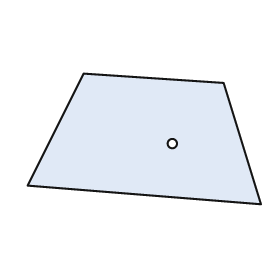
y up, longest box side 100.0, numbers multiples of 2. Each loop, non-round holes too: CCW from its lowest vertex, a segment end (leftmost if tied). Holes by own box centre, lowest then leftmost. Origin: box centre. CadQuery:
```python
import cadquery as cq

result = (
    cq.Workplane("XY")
    .moveTo(50.0, -28.0)
    .lineTo(34.0, 24.0)
    .lineTo(-26.0, 28.0)
    .lineTo(-50.0, -20.0)
    .close()
    .moveTo(12.0, -2.0)
    .circle(2.0)
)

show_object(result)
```